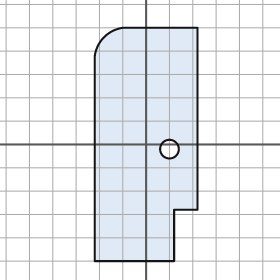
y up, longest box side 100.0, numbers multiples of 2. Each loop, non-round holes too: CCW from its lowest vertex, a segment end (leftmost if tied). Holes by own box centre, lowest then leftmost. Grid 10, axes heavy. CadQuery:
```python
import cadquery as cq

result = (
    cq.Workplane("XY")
    .moveTo(-22.0, -50.0)
    .lineTo(12.0, -50.0)
    .lineTo(12.0, -28.0)
    .lineTo(22.0, -28.0)
    .lineTo(22.0, 50.0)
    .lineTo(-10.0, 50.0)
    .threePointArc((-18.0, 46.0), (-22.0, 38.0))
    .close()
    .moveTo(10.0, -2.0)
    .circle(4.0)
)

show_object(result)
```